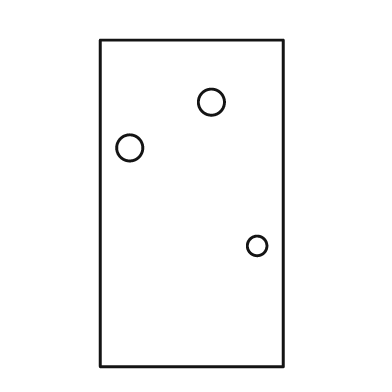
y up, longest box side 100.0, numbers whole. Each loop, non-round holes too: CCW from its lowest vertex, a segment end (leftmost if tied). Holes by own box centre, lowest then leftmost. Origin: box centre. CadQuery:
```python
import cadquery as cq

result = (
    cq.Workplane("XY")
    .moveTo(-28.0, -50.0)
    .lineTo(28.0, -50.0)
    .lineTo(28.0, 50.0)
    .lineTo(-28.0, 50.0)
    .close()
    .moveTo(20.0, -13.0)
    .circle(3.0)
    .moveTo(-19.0, 17.0)
    .circle(4.0)
    .moveTo(6.0, 31.0)
    .circle(4.0)
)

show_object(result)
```